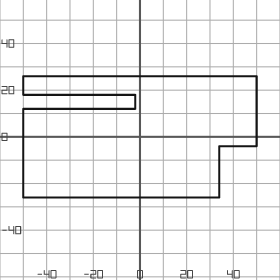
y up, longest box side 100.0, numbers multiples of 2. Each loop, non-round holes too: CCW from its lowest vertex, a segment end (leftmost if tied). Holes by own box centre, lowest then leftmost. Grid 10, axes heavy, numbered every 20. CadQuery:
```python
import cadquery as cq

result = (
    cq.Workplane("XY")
    .moveTo(-50.0, -26.0)
    .lineTo(34.0, -26.0)
    .lineTo(34.0, -4.0)
    .lineTo(50.0, -4.0)
    .lineTo(50.0, 26.0)
    .lineTo(-50.0, 26.0)
    .lineTo(-50.0, 18.0)
    .lineTo(-2.0, 18.0)
    .lineTo(-2.0, 12.0)
    .lineTo(-50.0, 12.0)
    .close()
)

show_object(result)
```